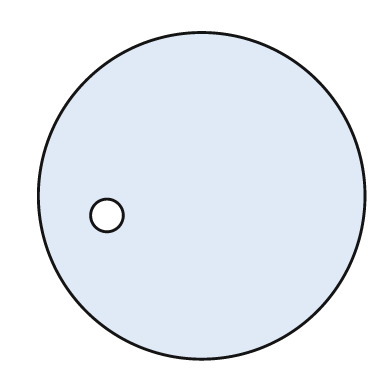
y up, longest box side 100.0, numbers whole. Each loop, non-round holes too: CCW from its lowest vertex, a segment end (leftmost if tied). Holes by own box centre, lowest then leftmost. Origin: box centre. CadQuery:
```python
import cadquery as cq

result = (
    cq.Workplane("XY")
    .moveTo(0.0, 0.0)
    .circle(50.0)
    .moveTo(-29.0, -6.0)
    .circle(5.0)
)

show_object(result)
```